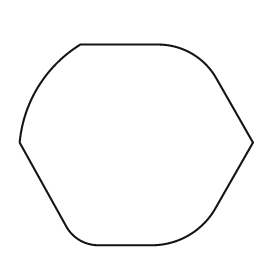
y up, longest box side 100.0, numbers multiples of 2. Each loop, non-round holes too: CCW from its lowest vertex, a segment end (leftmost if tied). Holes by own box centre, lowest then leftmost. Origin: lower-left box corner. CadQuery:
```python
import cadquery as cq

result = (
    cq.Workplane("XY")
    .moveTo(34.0, 0.0)
    .lineTo(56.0, 0.0)
    .threePointArc((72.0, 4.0), (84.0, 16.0))
    .lineTo(100.0, 44.0)
    .lineTo(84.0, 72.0)
    .threePointArc((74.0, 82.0), (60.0, 86.0))
    .lineTo(26.0, 86.0)
    .threePointArc((8.0, 68.0), (0.0, 44.0))
    .lineTo(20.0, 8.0)
    .threePointArc((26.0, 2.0), (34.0, 0.0))
    .close()
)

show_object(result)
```